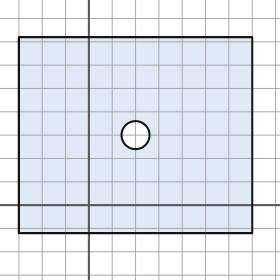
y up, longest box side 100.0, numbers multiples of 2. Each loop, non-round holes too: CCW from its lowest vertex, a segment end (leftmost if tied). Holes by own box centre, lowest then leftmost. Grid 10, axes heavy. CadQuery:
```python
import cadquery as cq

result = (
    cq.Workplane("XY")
    .moveTo(-30.0, -12.0)
    .lineTo(70.0, -12.0)
    .lineTo(70.0, 72.0)
    .lineTo(-30.0, 72.0)
    .close()
    .moveTo(20.0, 30.0)
    .circle(6.0)
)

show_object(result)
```